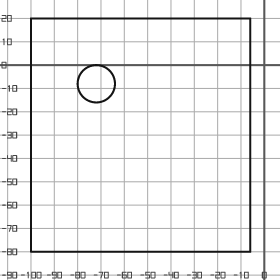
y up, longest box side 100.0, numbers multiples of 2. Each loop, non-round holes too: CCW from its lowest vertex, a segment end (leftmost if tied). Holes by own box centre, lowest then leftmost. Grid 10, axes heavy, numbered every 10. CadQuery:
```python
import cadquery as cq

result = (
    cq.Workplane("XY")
    .moveTo(-100.0, -80.0)
    .lineTo(-6.0, -80.0)
    .lineTo(-6.0, 20.0)
    .lineTo(-100.0, 20.0)
    .close()
    .moveTo(-72.0, -8.0)
    .circle(8.0)
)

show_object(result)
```